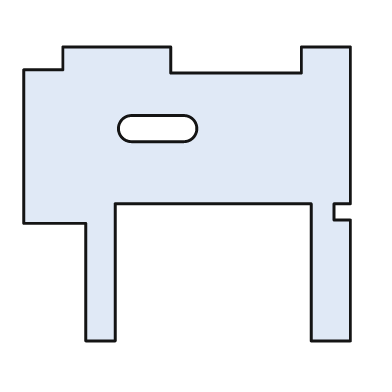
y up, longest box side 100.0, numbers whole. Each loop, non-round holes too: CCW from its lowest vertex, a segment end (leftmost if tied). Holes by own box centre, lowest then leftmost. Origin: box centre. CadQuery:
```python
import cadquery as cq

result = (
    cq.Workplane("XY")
    .moveTo(-31.0, -45.0)
    .lineTo(-22.0, -45.0)
    .lineTo(-22.0, -3.0)
    .lineTo(38.0, -3.0)
    .lineTo(38.0, -45.0)
    .lineTo(50.0, -45.0)
    .lineTo(50.0, -8.0)
    .lineTo(45.0, -8.0)
    .lineTo(45.0, -3.0)
    .lineTo(50.0, -3.0)
    .lineTo(50.0, 45.0)
    .lineTo(35.0, 45.0)
    .lineTo(35.0, 37.0)
    .lineTo(-5.0, 37.0)
    .lineTo(-5.0, 45.0)
    .lineTo(-38.0, 45.0)
    .lineTo(-38.0, 38.0)
    .lineTo(-50.0, 38.0)
    .lineTo(-50.0, -9.0)
    .lineTo(-31.0, -9.0)
    .close()
    .moveTo(-17.0, 16.0)
    .lineTo(-1.0, 16.0)
    .threePointArc((3.0, 20.0), (-1.0, 24.0))
    .lineTo(-17.0, 24.0)
    .threePointArc((-21.0, 20.0), (-17.0, 16.0))
    .close()
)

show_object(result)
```